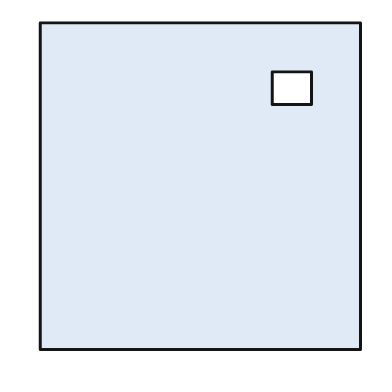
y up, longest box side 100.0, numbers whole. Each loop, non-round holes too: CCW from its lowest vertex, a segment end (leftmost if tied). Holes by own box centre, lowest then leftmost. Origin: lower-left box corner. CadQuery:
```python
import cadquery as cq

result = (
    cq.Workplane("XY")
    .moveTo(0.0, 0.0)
    .lineTo(98.0, 0.0)
    .lineTo(98.0, 100.0)
    .lineTo(0.0, 100.0)
    .close()
    .moveTo(71.0, 75.0)
    .lineTo(83.0, 75.0)
    .lineTo(83.0, 85.0)
    .lineTo(71.0, 85.0)
    .close()
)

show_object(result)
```